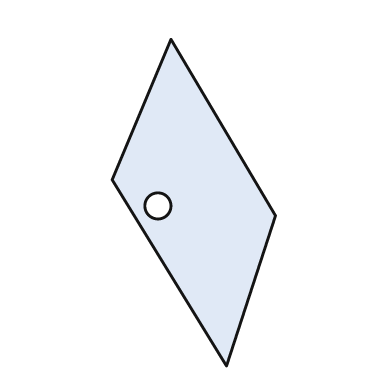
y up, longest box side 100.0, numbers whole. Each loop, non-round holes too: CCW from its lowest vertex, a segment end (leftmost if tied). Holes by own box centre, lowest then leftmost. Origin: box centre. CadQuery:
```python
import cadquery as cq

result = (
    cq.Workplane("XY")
    .moveTo(10.0, -50.0)
    .lineTo(25.0, -4.0)
    .lineTo(-7.0, 50.0)
    .lineTo(-25.0, 7.0)
    .close()
    .moveTo(-11.0, -1.0)
    .circle(4.0)
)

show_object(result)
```